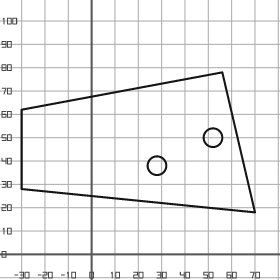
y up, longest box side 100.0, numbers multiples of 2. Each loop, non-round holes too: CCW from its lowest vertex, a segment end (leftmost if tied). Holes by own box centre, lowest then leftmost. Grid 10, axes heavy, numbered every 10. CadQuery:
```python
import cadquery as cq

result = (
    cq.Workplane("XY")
    .moveTo(70.0, 18.0)
    .lineTo(56.0, 78.0)
    .lineTo(-30.0, 62.0)
    .lineTo(-30.0, 28.0)
    .close()
    .moveTo(28.0, 38.0)
    .circle(4.0)
    .moveTo(52.0, 50.0)
    .circle(4.0)
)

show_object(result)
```